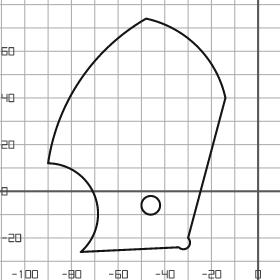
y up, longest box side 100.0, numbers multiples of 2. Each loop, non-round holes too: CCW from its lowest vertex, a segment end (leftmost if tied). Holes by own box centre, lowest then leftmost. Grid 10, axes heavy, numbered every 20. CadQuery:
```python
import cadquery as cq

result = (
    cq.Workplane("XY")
    .moveTo(-76.0, -26.0)
    .lineTo(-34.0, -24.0)
    .threePointArc((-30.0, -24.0), (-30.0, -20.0))
    .lineTo(-14.0, 40.0)
    .threePointArc((-26.0, 62.0), (-48.0, 74.0))
    .threePointArc((-76.0, 48.0), (-90.0, 12.0))
    .threePointArc((-70.0, -2.0), (-76.0, -26.0))
    .close()
    .moveTo(-46.0, -6.0)
    .circle(4.0)
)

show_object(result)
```